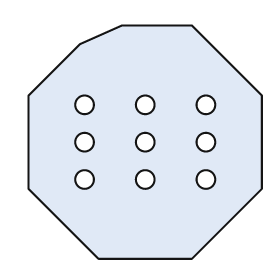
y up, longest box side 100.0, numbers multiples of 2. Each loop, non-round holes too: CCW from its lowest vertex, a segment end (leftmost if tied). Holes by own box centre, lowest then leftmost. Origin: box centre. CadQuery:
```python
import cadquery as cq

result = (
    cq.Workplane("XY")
    .moveTo(-20.0, -50.0)
    .lineTo(20.0, -50.0)
    .lineTo(50.0, -20.0)
    .lineTo(50.0, 20.0)
    .lineTo(20.0, 50.0)
    .lineTo(-10.0, 50.0)
    .lineTo(-28.0, 42.0)
    .lineTo(-50.0, 20.0)
    .lineTo(-50.0, -20.0)
    .close()
    .moveTo(-26.0, -16.0)
    .circle(4.0)
    .moveTo(0.0, -16.0)
    .circle(4.0)
    .moveTo(26.0, -16.0)
    .circle(4.0)
    .moveTo(-26.0, 0.0)
    .circle(4.0)
    .moveTo(0.0, 0.0)
    .circle(4.0)
    .moveTo(26.0, 0.0)
    .circle(4.0)
    .moveTo(-26.0, 16.0)
    .circle(4.0)
    .moveTo(0.0, 16.0)
    .circle(4.0)
    .moveTo(26.0, 16.0)
    .circle(4.0)
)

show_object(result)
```